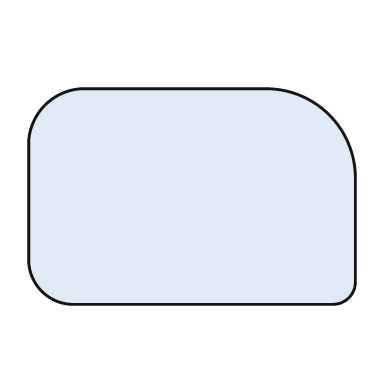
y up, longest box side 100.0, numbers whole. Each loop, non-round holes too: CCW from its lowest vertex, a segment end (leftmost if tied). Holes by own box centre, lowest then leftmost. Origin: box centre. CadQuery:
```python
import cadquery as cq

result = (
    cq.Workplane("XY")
    .moveTo(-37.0, -33.0)
    .lineTo(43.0, -33.0)
    .threePointArc((48.0, -31.0), (50.0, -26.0))
    .lineTo(50.0, 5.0)
    .threePointArc((42.0, 25.0), (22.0, 33.0))
    .lineTo(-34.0, 33.0)
    .threePointArc((-45.0, 28.0), (-50.0, 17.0))
    .lineTo(-50.0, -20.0)
    .threePointArc((-46.0, -29.0), (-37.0, -33.0))
    .close()
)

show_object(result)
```